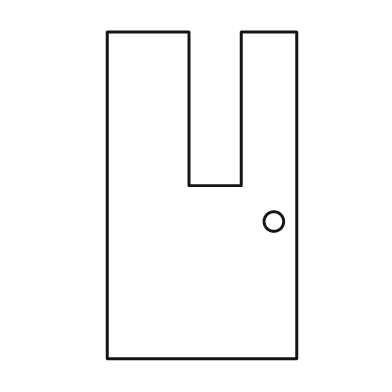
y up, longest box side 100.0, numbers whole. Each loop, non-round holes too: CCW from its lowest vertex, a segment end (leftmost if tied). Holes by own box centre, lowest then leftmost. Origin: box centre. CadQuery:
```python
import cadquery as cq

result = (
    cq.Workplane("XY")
    .moveTo(-29.0, -50.0)
    .lineTo(29.0, -50.0)
    .lineTo(29.0, 50.0)
    .lineTo(12.0, 50.0)
    .lineTo(12.0, 3.0)
    .lineTo(-4.0, 3.0)
    .lineTo(-4.0, 50.0)
    .lineTo(-29.0, 50.0)
    .close()
    .moveTo(22.0, -8.0)
    .circle(3.0)
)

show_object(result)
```